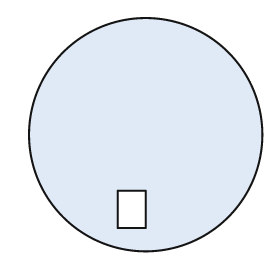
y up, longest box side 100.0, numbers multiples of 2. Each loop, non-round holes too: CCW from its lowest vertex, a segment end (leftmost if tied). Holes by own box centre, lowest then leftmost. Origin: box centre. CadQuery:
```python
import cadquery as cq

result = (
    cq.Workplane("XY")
    .moveTo(0.0, 0.0)
    .circle(50.0)
    .moveTo(-12.0, -40.0)
    .lineTo(0.0, -40.0)
    .lineTo(0.0, -24.0)
    .lineTo(-12.0, -24.0)
    .close()
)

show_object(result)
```